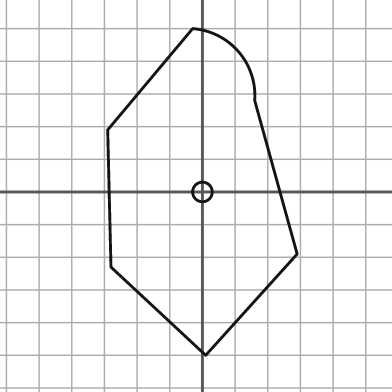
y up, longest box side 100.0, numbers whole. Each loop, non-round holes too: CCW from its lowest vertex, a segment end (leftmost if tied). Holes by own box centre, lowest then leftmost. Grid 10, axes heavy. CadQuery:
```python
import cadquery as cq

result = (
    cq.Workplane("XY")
    .moveTo(1.0, -50.0)
    .lineTo(29.0, -19.0)
    .lineTo(16.0, 28.0)
    .threePointArc((11.0, 43.0), (-3.0, 50.0))
    .lineTo(-29.0, 19.0)
    .lineTo(-28.0, -23.0)
    .close()
    .moveTo(0.0, 0.0)
    .circle(3.0)
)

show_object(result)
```